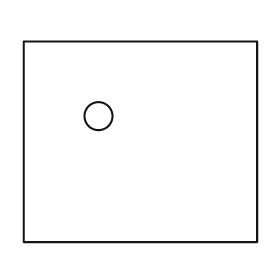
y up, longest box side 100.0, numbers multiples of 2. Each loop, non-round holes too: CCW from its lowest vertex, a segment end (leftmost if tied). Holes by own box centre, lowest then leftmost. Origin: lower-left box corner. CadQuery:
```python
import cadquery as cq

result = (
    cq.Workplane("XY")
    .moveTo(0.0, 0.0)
    .lineTo(100.0, 0.0)
    .lineTo(100.0, 86.0)
    .lineTo(0.0, 86.0)
    .close()
    .moveTo(32.0, 54.0)
    .circle(6.0)
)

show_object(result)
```